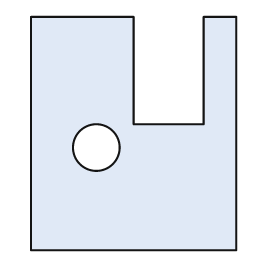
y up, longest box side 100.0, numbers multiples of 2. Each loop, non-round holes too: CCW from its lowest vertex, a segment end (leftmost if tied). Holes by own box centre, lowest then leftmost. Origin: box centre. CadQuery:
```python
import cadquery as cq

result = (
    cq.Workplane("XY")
    .moveTo(-44.0, -50.0)
    .lineTo(44.0, -50.0)
    .lineTo(44.0, 50.0)
    .lineTo(30.0, 50.0)
    .lineTo(30.0, 4.0)
    .lineTo(0.0, 4.0)
    .lineTo(0.0, 50.0)
    .lineTo(-44.0, 50.0)
    .close()
    .moveTo(-16.0, -6.0)
    .circle(10.0)
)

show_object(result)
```